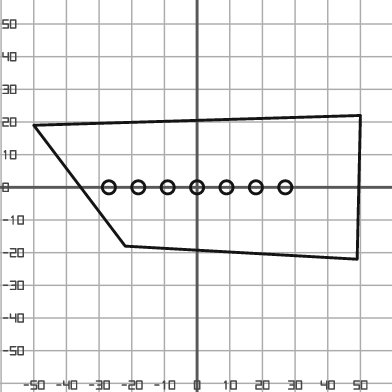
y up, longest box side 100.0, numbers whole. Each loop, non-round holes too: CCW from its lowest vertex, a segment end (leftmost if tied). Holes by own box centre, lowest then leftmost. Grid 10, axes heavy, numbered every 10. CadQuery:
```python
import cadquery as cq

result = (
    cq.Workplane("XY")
    .moveTo(49.0, -22.0)
    .lineTo(50.0, 22.0)
    .lineTo(-50.0, 19.0)
    .lineTo(-22.0, -18.0)
    .close()
    .moveTo(-27.0, 0.0)
    .circle(2.0)
    .moveTo(-18.0, 0.0)
    .circle(2.0)
    .moveTo(-9.0, 0.0)
    .circle(2.0)
    .moveTo(0.0, 0.0)
    .circle(2.0)
    .moveTo(9.0, 0.0)
    .circle(2.0)
    .moveTo(18.0, 0.0)
    .circle(2.0)
    .moveTo(27.0, 0.0)
    .circle(2.0)
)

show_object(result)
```